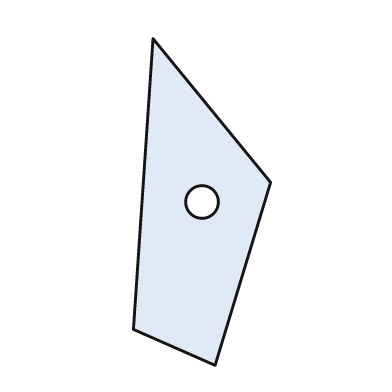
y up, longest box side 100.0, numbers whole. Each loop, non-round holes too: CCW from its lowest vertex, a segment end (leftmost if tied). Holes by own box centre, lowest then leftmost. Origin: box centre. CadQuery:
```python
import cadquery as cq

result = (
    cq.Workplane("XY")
    .moveTo(4.0, -50.0)
    .lineTo(21.0, 6.0)
    .lineTo(-15.0, 50.0)
    .lineTo(-21.0, -39.0)
    .close()
    .moveTo(0.0, 0.0)
    .circle(5.0)
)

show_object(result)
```